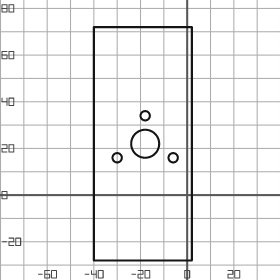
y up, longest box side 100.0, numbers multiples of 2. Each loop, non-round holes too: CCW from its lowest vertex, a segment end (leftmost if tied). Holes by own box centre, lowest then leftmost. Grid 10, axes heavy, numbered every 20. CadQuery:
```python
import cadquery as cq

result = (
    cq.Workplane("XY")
    .moveTo(-40.0, -28.0)
    .lineTo(2.0, -28.0)
    .lineTo(2.0, 72.0)
    .lineTo(-40.0, 72.0)
    .close()
    .moveTo(-30.0, 16.0)
    .circle(2.0)
    .moveTo(-6.0, 16.0)
    .circle(2.0)
    .moveTo(-18.0, 22.0)
    .circle(6.0)
    .moveTo(-18.0, 34.0)
    .circle(2.0)
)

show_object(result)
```